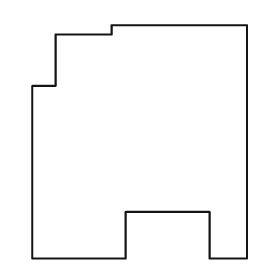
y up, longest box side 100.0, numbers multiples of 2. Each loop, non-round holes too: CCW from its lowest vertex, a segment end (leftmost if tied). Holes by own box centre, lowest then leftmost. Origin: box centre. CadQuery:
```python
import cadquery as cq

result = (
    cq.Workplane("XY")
    .moveTo(-46.0, -50.0)
    .lineTo(-6.0, -50.0)
    .lineTo(-6.0, -30.0)
    .lineTo(30.0, -30.0)
    .lineTo(30.0, -50.0)
    .lineTo(46.0, -50.0)
    .lineTo(46.0, 50.0)
    .lineTo(-12.0, 50.0)
    .lineTo(-12.0, 46.0)
    .lineTo(-36.0, 46.0)
    .lineTo(-36.0, 24.0)
    .lineTo(-46.0, 24.0)
    .close()
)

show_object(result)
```